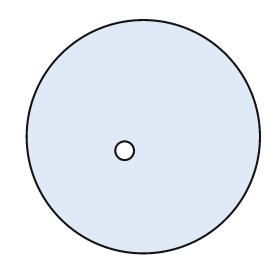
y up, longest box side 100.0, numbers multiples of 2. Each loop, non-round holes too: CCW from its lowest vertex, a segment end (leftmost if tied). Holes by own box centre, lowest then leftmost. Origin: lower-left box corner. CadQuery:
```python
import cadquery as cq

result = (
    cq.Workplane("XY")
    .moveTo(50.0, 50.0)
    .circle(50.0)
    .moveTo(42.0, 44.0)
    .circle(4.0)
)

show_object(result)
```